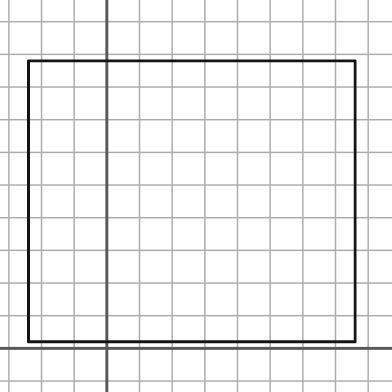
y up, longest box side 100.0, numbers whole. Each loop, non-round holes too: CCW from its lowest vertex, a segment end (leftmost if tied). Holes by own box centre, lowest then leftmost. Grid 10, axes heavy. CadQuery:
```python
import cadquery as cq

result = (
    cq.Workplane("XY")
    .moveTo(-24.0, 2.0)
    .lineTo(76.0, 2.0)
    .lineTo(76.0, 88.0)
    .lineTo(-24.0, 88.0)
    .close()
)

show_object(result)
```